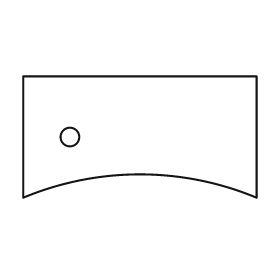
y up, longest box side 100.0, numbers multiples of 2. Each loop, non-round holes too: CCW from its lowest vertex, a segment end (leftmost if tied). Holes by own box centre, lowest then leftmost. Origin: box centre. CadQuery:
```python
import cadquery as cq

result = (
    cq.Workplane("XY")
    .moveTo(-50.0, -26.0)
    .threePointArc((0.0, -16.0), (50.0, -26.0))
    .lineTo(50.0, 26.0)
    .lineTo(-50.0, 26.0)
    .close()
    .moveTo(-30.0, 0.0)
    .circle(4.0)
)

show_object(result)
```